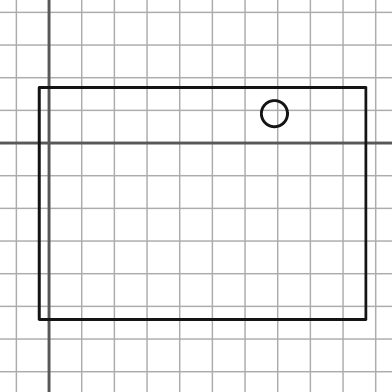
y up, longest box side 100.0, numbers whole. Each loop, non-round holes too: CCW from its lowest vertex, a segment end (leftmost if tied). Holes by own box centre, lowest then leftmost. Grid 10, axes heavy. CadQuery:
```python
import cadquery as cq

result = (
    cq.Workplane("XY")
    .moveTo(-3.0, -54.0)
    .lineTo(97.0, -54.0)
    .lineTo(97.0, 17.0)
    .lineTo(-3.0, 17.0)
    .close()
    .moveTo(69.0, 9.0)
    .circle(4.0)
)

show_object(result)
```